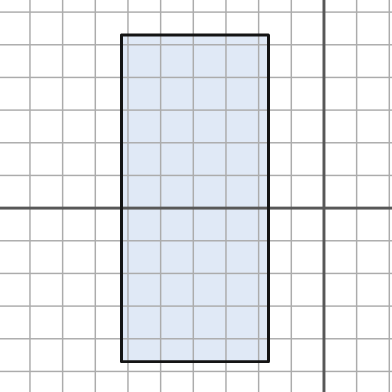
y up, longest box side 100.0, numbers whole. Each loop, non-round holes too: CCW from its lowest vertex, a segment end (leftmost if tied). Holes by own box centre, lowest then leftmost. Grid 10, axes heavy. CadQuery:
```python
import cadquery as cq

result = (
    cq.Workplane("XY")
    .moveTo(-62.0, -47.0)
    .lineTo(-17.0, -47.0)
    .lineTo(-17.0, 53.0)
    .lineTo(-62.0, 53.0)
    .close()
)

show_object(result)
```